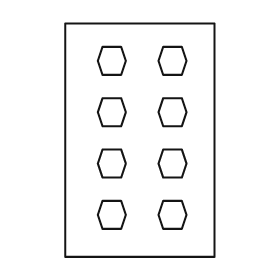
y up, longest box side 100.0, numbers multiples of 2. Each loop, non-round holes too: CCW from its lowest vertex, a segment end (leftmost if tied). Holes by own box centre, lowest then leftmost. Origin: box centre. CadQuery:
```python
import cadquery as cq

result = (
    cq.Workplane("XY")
    .moveTo(-32.0, -50.0)
    .lineTo(32.0, -50.0)
    .lineTo(32.0, 50.0)
    .lineTo(-32.0, 50.0)
    .close()
    .moveTo(-16.0, -38.0)
    .lineTo(-8.0, -38.0)
    .lineTo(-6.0, -32.0)
    .lineTo(-8.0, -26.0)
    .lineTo(-16.0, -26.0)
    .lineTo(-18.0, -32.0)
    .close()
    .moveTo(10.0, -38.0)
    .lineTo(18.0, -38.0)
    .lineTo(20.0, -32.0)
    .lineTo(18.0, -26.0)
    .lineTo(10.0, -26.0)
    .lineTo(8.0, -32.0)
    .close()
    .moveTo(-16.0, -16.0)
    .lineTo(-8.0, -16.0)
    .lineTo(-6.0, -10.0)
    .lineTo(-8.0, -4.0)
    .lineTo(-16.0, -4.0)
    .lineTo(-18.0, -10.0)
    .close()
    .moveTo(10.0, -16.0)
    .lineTo(18.0, -16.0)
    .lineTo(20.0, -10.0)
    .lineTo(18.0, -4.0)
    .lineTo(10.0, -4.0)
    .lineTo(8.0, -10.0)
    .close()
    .moveTo(-16.0, 6.0)
    .lineTo(-8.0, 6.0)
    .lineTo(-6.0, 12.0)
    .lineTo(-8.0, 18.0)
    .lineTo(-16.0, 18.0)
    .lineTo(-18.0, 12.0)
    .close()
    .moveTo(10.0, 6.0)
    .lineTo(18.0, 6.0)
    .lineTo(20.0, 12.0)
    .lineTo(18.0, 18.0)
    .lineTo(10.0, 18.0)
    .lineTo(8.0, 12.0)
    .close()
    .moveTo(-16.0, 28.0)
    .lineTo(-8.0, 28.0)
    .lineTo(-6.0, 34.0)
    .lineTo(-8.0, 40.0)
    .lineTo(-16.0, 40.0)
    .lineTo(-18.0, 34.0)
    .close()
    .moveTo(10.0, 28.0)
    .lineTo(18.0, 28.0)
    .lineTo(20.0, 34.0)
    .lineTo(18.0, 40.0)
    .lineTo(10.0, 40.0)
    .lineTo(8.0, 34.0)
    .close()
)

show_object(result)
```